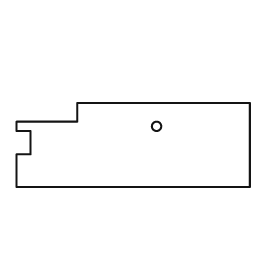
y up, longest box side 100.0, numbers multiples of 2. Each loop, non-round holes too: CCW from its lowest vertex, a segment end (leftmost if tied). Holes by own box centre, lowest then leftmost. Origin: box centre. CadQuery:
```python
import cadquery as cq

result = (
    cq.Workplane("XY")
    .moveTo(-50.0, -18.0)
    .lineTo(50.0, -18.0)
    .lineTo(50.0, 18.0)
    .lineTo(-24.0, 18.0)
    .lineTo(-24.0, 10.0)
    .lineTo(-50.0, 10.0)
    .lineTo(-50.0, 6.0)
    .lineTo(-44.0, 6.0)
    .lineTo(-44.0, -4.0)
    .lineTo(-50.0, -4.0)
    .close()
    .moveTo(10.0, 8.0)
    .circle(2.0)
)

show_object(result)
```